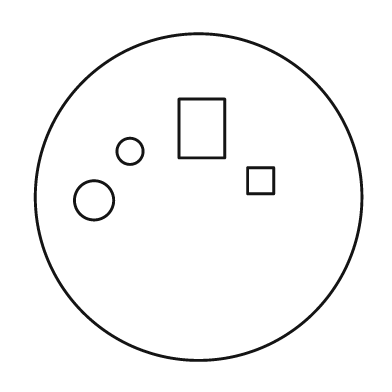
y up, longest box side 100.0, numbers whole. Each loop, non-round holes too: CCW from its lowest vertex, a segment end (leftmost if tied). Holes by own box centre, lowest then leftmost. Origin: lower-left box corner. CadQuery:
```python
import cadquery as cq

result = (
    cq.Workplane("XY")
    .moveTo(50.0, 50.0)
    .circle(50.0)
    .moveTo(18.0, 49.0)
    .circle(6.0)
    .moveTo(65.0, 51.0)
    .lineTo(73.0, 51.0)
    .lineTo(73.0, 59.0)
    .lineTo(65.0, 59.0)
    .close()
    .moveTo(29.0, 64.0)
    .circle(4.0)
    .moveTo(44.0, 62.0)
    .lineTo(58.0, 62.0)
    .lineTo(58.0, 80.0)
    .lineTo(44.0, 80.0)
    .close()
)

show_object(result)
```